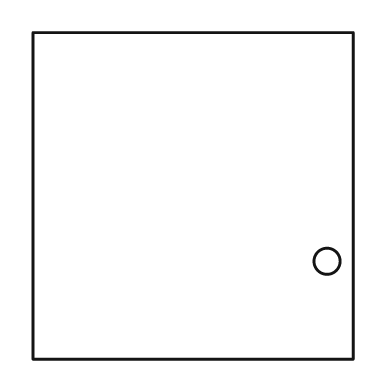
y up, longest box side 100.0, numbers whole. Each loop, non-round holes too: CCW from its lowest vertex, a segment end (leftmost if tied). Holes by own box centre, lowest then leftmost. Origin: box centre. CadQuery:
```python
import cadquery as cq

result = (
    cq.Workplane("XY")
    .moveTo(-49.0, -50.0)
    .lineTo(49.0, -50.0)
    .lineTo(49.0, 50.0)
    .lineTo(-49.0, 50.0)
    .close()
    .moveTo(41.0, -20.0)
    .circle(4.0)
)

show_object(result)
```